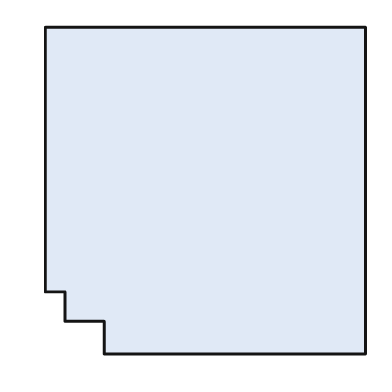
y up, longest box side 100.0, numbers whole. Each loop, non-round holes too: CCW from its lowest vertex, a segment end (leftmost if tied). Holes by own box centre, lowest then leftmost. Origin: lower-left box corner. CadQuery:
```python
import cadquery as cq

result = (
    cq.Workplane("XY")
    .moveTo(18.0, 0.0)
    .lineTo(98.0, 0.0)
    .lineTo(98.0, 100.0)
    .lineTo(0.0, 100.0)
    .lineTo(0.0, 19.0)
    .lineTo(6.0, 19.0)
    .lineTo(6.0, 10.0)
    .lineTo(18.0, 10.0)
    .close()
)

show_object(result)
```